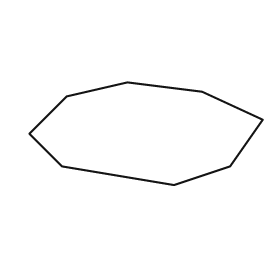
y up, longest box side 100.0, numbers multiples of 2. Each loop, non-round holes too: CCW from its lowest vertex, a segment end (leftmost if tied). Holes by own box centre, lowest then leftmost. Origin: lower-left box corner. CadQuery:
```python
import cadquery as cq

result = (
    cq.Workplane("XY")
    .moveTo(62.0, 0.0)
    .lineTo(86.0, 8.0)
    .lineTo(100.0, 28.0)
    .lineTo(74.0, 40.0)
    .lineTo(42.0, 44.0)
    .lineTo(16.0, 38.0)
    .lineTo(0.0, 22.0)
    .lineTo(14.0, 8.0)
    .close()
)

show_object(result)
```